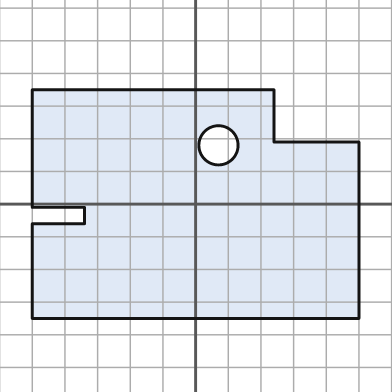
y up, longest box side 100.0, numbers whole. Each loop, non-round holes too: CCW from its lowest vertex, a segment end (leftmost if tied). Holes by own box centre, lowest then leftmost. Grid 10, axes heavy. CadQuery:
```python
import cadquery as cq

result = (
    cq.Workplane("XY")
    .moveTo(-50.0, -35.0)
    .lineTo(50.0, -35.0)
    .lineTo(50.0, 19.0)
    .lineTo(24.0, 19.0)
    .lineTo(24.0, 35.0)
    .lineTo(-50.0, 35.0)
    .lineTo(-50.0, -1.0)
    .lineTo(-34.0, -1.0)
    .lineTo(-34.0, -6.0)
    .lineTo(-50.0, -6.0)
    .close()
    .moveTo(7.0, 18.0)
    .circle(6.0)
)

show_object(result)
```